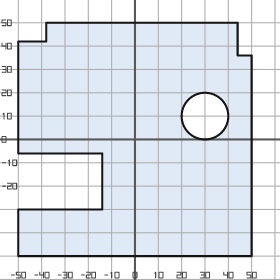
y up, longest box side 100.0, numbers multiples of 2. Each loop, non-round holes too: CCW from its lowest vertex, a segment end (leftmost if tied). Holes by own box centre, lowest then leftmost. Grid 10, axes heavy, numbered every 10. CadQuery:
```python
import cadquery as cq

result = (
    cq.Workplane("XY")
    .moveTo(-50.0, -50.0)
    .lineTo(50.0, -50.0)
    .lineTo(50.0, 36.0)
    .lineTo(44.0, 36.0)
    .lineTo(44.0, 50.0)
    .lineTo(-38.0, 50.0)
    .lineTo(-38.0, 42.0)
    .lineTo(-50.0, 42.0)
    .lineTo(-50.0, -6.0)
    .lineTo(-14.0, -6.0)
    .lineTo(-14.0, -30.0)
    .lineTo(-50.0, -30.0)
    .close()
    .moveTo(30.0, 10.0)
    .circle(10.0)
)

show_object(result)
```